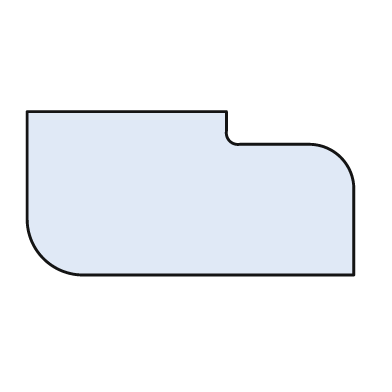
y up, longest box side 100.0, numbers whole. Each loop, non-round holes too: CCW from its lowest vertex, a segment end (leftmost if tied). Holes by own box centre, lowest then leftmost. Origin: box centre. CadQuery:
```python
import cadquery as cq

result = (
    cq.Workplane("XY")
    .moveTo(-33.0, -25.0)
    .lineTo(50.0, -25.0)
    .lineTo(50.0, 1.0)
    .threePointArc((46.0, 11.0), (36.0, 15.0))
    .lineTo(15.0, 15.0)
    .threePointArc((12.0, 16.0), (11.0, 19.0))
    .lineTo(11.0, 25.0)
    .lineTo(-50.0, 25.0)
    .lineTo(-50.0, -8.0)
    .threePointArc((-45.0, -20.0), (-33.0, -25.0))
    .close()
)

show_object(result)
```